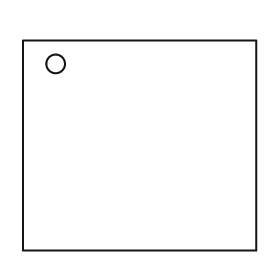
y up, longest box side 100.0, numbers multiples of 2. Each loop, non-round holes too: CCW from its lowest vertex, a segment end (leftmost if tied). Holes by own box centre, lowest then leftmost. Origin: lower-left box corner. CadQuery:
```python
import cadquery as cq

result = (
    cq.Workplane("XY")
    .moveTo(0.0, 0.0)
    .lineTo(100.0, 0.0)
    .lineTo(100.0, 90.0)
    .lineTo(0.0, 90.0)
    .close()
    .moveTo(14.0, 80.0)
    .circle(4.0)
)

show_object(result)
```